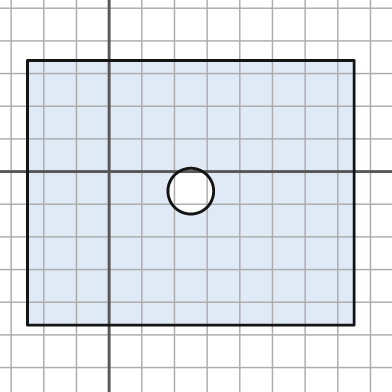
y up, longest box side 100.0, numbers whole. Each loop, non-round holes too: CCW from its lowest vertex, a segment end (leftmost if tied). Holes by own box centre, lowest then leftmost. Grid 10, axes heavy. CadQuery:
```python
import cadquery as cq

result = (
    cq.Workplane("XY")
    .moveTo(-25.0, -47.0)
    .lineTo(75.0, -47.0)
    .lineTo(75.0, 34.0)
    .lineTo(-25.0, 34.0)
    .close()
    .moveTo(25.0, -6.0)
    .circle(7.0)
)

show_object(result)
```